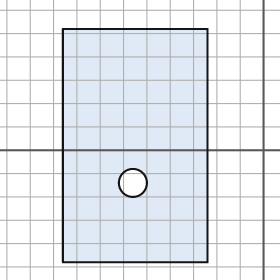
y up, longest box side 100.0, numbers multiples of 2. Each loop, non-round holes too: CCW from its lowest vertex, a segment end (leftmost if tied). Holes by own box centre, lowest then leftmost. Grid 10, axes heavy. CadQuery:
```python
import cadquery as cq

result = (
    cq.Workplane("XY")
    .moveTo(-86.0, -48.0)
    .lineTo(-24.0, -48.0)
    .lineTo(-24.0, 52.0)
    .lineTo(-86.0, 52.0)
    .close()
    .moveTo(-56.0, -14.0)
    .circle(6.0)
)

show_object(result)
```